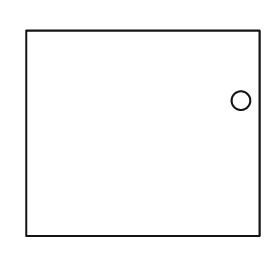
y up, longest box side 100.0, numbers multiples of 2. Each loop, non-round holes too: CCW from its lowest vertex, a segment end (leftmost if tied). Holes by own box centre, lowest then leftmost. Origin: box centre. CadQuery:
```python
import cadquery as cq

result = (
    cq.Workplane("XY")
    .moveTo(-50.0, -44.0)
    .lineTo(50.0, -44.0)
    .lineTo(50.0, 44.0)
    .lineTo(-50.0, 44.0)
    .close()
    .moveTo(42.0, 14.0)
    .circle(4.0)
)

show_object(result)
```